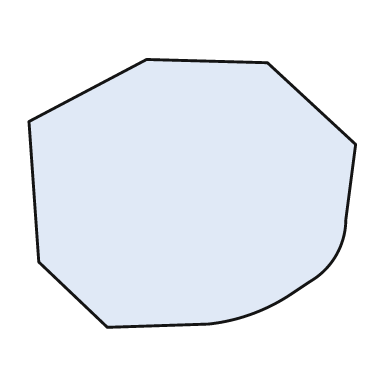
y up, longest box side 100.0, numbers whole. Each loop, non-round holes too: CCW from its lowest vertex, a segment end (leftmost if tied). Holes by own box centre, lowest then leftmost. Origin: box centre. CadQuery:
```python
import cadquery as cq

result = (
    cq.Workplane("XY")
    .moveTo(-26.0, -41.0)
    .lineTo(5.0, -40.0)
    .threePointArc((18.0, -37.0), (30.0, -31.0))
    .lineTo(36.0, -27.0)
    .threePointArc((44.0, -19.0), (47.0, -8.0))
    .lineTo(50.0, 15.0)
    .lineTo(23.0, 40.0)
    .lineTo(-14.0, 41.0)
    .lineTo(-50.0, 22.0)
    .lineTo(-47.0, -21.0)
    .close()
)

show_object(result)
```